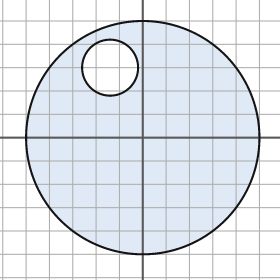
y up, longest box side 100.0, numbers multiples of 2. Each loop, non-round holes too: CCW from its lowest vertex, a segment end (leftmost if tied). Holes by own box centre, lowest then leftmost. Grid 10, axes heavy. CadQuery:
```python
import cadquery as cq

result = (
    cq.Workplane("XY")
    .moveTo(0.0, 0.0)
    .circle(50.0)
    .moveTo(-14.0, 30.0)
    .circle(12.0)
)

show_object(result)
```